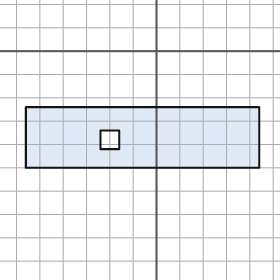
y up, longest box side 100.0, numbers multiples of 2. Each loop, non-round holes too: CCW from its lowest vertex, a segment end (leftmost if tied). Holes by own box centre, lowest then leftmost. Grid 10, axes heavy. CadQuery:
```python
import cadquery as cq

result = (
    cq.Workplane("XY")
    .moveTo(-56.0, -50.0)
    .lineTo(44.0, -50.0)
    .lineTo(44.0, -24.0)
    .lineTo(-56.0, -24.0)
    .close()
    .moveTo(-24.0, -42.0)
    .lineTo(-16.0, -42.0)
    .lineTo(-16.0, -34.0)
    .lineTo(-24.0, -34.0)
    .close()
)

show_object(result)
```